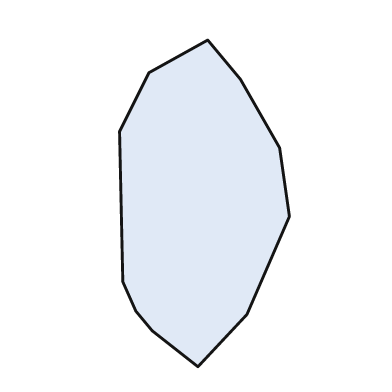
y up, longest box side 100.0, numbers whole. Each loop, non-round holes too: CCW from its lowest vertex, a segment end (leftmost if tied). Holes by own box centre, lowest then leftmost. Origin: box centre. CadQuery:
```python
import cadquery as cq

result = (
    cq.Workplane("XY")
    .moveTo(-2.0, -50.0)
    .lineTo(13.0, -34.0)
    .lineTo(26.0, -4.0)
    .lineTo(23.0, 17.0)
    .lineTo(11.0, 38.0)
    .lineTo(1.0, 50.0)
    .lineTo(-17.0, 40.0)
    .lineTo(-26.0, 22.0)
    .lineTo(-25.0, -24.0)
    .lineTo(-21.0, -33.0)
    .lineTo(-16.0, -39.0)
    .close()
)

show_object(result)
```